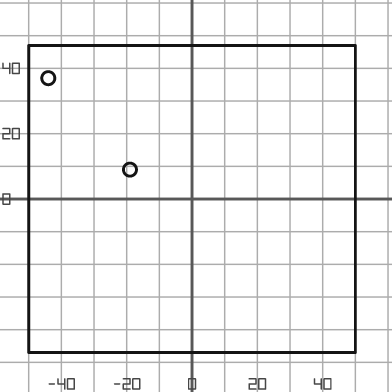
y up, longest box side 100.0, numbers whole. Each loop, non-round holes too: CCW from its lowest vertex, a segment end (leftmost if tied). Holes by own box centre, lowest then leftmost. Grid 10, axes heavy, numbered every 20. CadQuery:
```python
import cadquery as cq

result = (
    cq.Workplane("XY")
    .moveTo(-50.0, -47.0)
    .lineTo(50.0, -47.0)
    .lineTo(50.0, 47.0)
    .lineTo(-50.0, 47.0)
    .close()
    .moveTo(-19.0, 9.0)
    .circle(2.0)
    .moveTo(-44.0, 37.0)
    .circle(2.0)
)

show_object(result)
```